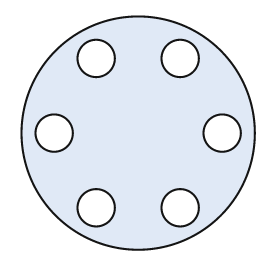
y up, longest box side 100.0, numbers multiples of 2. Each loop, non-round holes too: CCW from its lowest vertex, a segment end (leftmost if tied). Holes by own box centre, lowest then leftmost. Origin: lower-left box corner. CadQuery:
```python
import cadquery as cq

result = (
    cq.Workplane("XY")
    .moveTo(50.0, 50.0)
    .circle(50.0)
    .moveTo(32.0, 18.0)
    .circle(8.0)
    .moveTo(68.0, 18.0)
    .circle(8.0)
    .moveTo(14.0, 50.0)
    .circle(8.0)
    .moveTo(86.0, 50.0)
    .circle(8.0)
    .moveTo(32.0, 82.0)
    .circle(8.0)
    .moveTo(68.0, 82.0)
    .circle(8.0)
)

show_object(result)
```